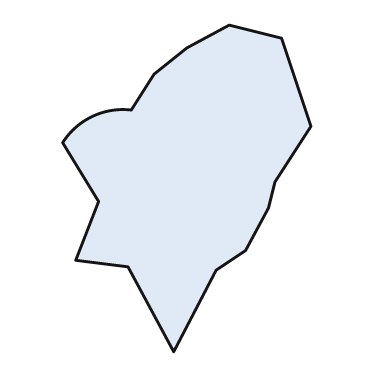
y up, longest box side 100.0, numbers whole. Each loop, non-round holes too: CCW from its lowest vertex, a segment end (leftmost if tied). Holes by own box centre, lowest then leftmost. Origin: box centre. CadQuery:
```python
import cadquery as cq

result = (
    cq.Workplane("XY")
    .moveTo(-4.0, -50.0)
    .lineTo(9.0, -25.0)
    .lineTo(18.0, -19.0)
    .lineTo(25.0, -6.0)
    .lineTo(27.0, 2.0)
    .lineTo(38.0, 19.0)
    .lineTo(29.0, 46.0)
    .lineTo(13.0, 50.0)
    .lineTo(0.0, 43.0)
    .lineTo(-10.0, 35.0)
    .lineTo(-17.0, 24.0)
    .threePointArc((-29.0, 22.0), (-38.0, 14.0))
    .lineTo(-27.0, -4.0)
    .lineTo(-34.0, -22.0)
    .lineTo(-18.0, -24.0)
    .close()
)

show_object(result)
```